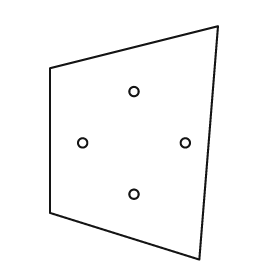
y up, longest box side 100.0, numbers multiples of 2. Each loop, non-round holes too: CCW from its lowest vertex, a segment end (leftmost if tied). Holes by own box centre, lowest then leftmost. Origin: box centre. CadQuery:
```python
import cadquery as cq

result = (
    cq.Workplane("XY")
    .moveTo(28.0, -50.0)
    .lineTo(36.0, 50.0)
    .lineTo(-36.0, 32.0)
    .lineTo(-36.0, -30.0)
    .close()
    .moveTo(0.0, -22.0)
    .circle(2.0)
    .moveTo(-22.0, 0.0)
    .circle(2.0)
    .moveTo(22.0, 0.0)
    .circle(2.0)
    .moveTo(0.0, 22.0)
    .circle(2.0)
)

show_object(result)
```